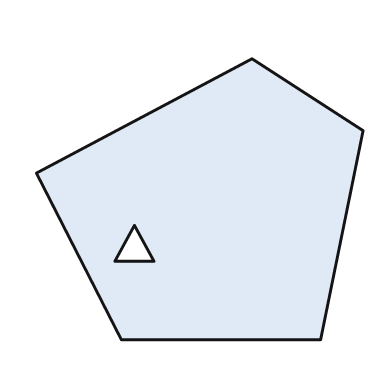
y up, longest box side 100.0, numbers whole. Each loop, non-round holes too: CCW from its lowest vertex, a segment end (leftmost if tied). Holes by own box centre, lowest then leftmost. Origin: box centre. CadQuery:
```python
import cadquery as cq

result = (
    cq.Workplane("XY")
    .moveTo(-24.0, -43.0)
    .lineTo(37.0, -43.0)
    .lineTo(50.0, 21.0)
    .lineTo(16.0, 43.0)
    .lineTo(-50.0, 8.0)
    .close()
    .moveTo(-26.0, -19.0)
    .lineTo(-14.0, -19.0)
    .lineTo(-20.0, -8.0)
    .close()
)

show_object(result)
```